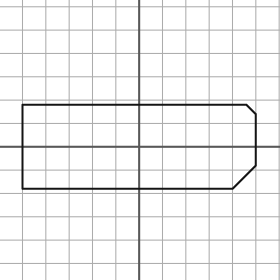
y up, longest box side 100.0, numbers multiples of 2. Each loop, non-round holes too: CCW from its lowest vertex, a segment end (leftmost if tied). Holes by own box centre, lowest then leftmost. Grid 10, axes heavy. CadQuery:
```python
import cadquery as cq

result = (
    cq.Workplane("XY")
    .moveTo(-50.0, -18.0)
    .lineTo(40.0, -18.0)
    .lineTo(50.0, -8.0)
    .lineTo(50.0, 14.0)
    .lineTo(46.0, 18.0)
    .lineTo(-50.0, 18.0)
    .close()
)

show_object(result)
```